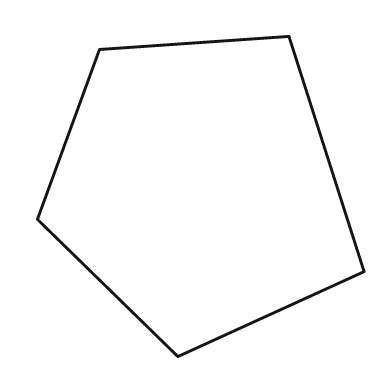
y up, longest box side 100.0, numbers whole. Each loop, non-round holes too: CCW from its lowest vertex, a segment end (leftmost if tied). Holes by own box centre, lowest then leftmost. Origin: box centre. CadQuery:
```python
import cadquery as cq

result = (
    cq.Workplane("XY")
    .moveTo(-7.0, -49.0)
    .lineTo(50.0, -23.0)
    .lineTo(27.0, 49.0)
    .lineTo(-31.0, 45.0)
    .lineTo(-50.0, -7.0)
    .close()
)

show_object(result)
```